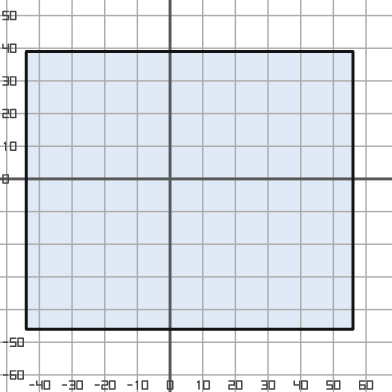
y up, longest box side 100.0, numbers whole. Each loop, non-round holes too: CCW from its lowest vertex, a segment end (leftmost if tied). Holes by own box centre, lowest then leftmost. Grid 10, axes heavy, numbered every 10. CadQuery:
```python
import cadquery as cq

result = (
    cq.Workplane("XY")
    .moveTo(-44.0, -46.0)
    .lineTo(56.0, -46.0)
    .lineTo(56.0, 39.0)
    .lineTo(-44.0, 39.0)
    .close()
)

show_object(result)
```